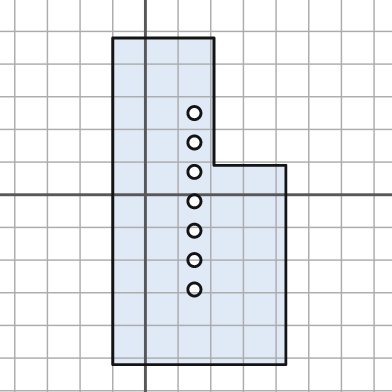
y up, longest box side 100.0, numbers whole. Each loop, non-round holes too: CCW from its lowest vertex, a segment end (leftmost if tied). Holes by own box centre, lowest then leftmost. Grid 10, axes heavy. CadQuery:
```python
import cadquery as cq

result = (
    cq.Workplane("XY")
    .moveTo(-10.0, -52.0)
    .lineTo(43.0, -52.0)
    .lineTo(43.0, 9.0)
    .lineTo(21.0, 9.0)
    .lineTo(21.0, 48.0)
    .lineTo(-10.0, 48.0)
    .close()
    .moveTo(15.0, -29.0)
    .circle(2.0)
    .moveTo(15.0, -20.0)
    .circle(2.0)
    .moveTo(15.0, -11.0)
    .circle(2.0)
    .moveTo(15.0, -2.0)
    .circle(2.0)
    .moveTo(15.0, 7.0)
    .circle(2.0)
    .moveTo(15.0, 16.0)
    .circle(2.0)
    .moveTo(15.0, 25.0)
    .circle(2.0)
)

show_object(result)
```